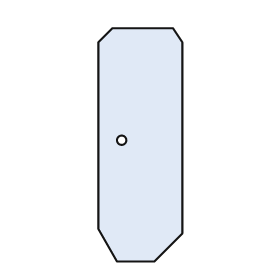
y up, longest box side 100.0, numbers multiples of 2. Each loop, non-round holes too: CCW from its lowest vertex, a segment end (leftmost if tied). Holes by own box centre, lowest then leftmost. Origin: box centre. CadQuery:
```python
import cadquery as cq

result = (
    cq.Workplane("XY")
    .moveTo(-10.0, -50.0)
    .lineTo(6.0, -50.0)
    .lineTo(18.0, -38.0)
    .lineTo(18.0, 44.0)
    .lineTo(14.0, 50.0)
    .lineTo(-12.0, 50.0)
    .lineTo(-18.0, 44.0)
    .lineTo(-18.0, -36.0)
    .close()
    .moveTo(-8.0, 2.0)
    .circle(2.0)
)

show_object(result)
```